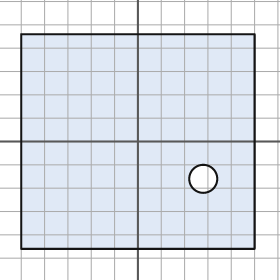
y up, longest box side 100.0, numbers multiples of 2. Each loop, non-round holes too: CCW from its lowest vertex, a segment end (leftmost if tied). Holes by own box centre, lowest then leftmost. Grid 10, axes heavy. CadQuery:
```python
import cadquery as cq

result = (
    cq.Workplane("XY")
    .moveTo(-50.0, -46.0)
    .lineTo(50.0, -46.0)
    .lineTo(50.0, 46.0)
    .lineTo(-50.0, 46.0)
    .close()
    .moveTo(28.0, -16.0)
    .circle(6.0)
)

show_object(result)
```